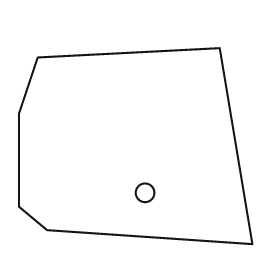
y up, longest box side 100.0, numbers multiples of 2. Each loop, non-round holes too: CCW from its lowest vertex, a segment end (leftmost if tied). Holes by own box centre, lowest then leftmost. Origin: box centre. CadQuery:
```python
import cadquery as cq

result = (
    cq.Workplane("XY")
    .moveTo(50.0, -42.0)
    .lineTo(36.0, 42.0)
    .lineTo(-42.0, 38.0)
    .lineTo(-50.0, 14.0)
    .lineTo(-50.0, -26.0)
    .lineTo(-38.0, -36.0)
    .close()
    .moveTo(4.0, -20.0)
    .circle(4.0)
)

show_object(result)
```